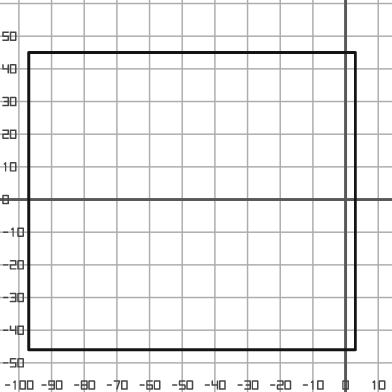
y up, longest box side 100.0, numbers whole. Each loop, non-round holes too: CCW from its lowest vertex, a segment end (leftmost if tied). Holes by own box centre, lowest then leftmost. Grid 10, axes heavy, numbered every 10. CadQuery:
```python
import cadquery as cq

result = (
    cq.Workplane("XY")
    .moveTo(-97.0, -46.0)
    .lineTo(3.0, -46.0)
    .lineTo(3.0, 45.0)
    .lineTo(-97.0, 45.0)
    .close()
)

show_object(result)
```